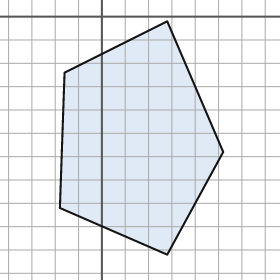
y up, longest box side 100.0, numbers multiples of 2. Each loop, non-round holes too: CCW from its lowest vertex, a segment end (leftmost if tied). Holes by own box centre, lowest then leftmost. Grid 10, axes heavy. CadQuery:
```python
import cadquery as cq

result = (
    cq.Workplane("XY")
    .moveTo(28.0, -102.0)
    .lineTo(52.0, -58.0)
    .lineTo(28.0, -2.0)
    .lineTo(-16.0, -24.0)
    .lineTo(-18.0, -82.0)
    .close()
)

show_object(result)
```